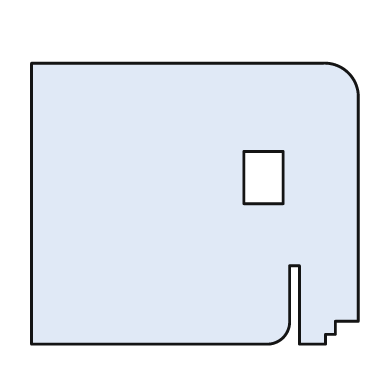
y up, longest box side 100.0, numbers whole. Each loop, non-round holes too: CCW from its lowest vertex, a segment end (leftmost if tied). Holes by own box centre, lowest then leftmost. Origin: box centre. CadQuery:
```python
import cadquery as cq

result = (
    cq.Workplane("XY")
    .moveTo(-50.0, -43.0)
    .lineTo(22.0, -43.0)
    .threePointArc((27.0, -41.0), (29.0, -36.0))
    .lineTo(29.0, -19.0)
    .lineTo(32.0, -19.0)
    .lineTo(32.0, -43.0)
    .lineTo(40.0, -43.0)
    .lineTo(40.0, -40.0)
    .lineTo(43.0, -40.0)
    .lineTo(43.0, -36.0)
    .lineTo(50.0, -36.0)
    .lineTo(50.0, 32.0)
    .threePointArc((47.0, 40.0), (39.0, 43.0))
    .lineTo(-50.0, 43.0)
    .close()
    .moveTo(15.0, 0.0)
    .lineTo(27.0, 0.0)
    .lineTo(27.0, 16.0)
    .lineTo(15.0, 16.0)
    .close()
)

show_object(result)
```